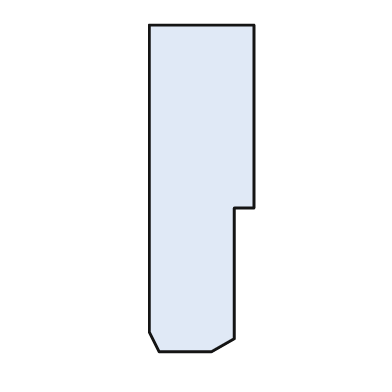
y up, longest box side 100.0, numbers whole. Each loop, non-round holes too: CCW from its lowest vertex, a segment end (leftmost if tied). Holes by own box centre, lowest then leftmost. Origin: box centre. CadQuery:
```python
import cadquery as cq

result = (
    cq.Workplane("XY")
    .moveTo(-13.0, -50.0)
    .lineTo(3.0, -50.0)
    .lineTo(10.0, -46.0)
    .lineTo(10.0, -6.0)
    .lineTo(16.0, -6.0)
    .lineTo(16.0, 50.0)
    .lineTo(-16.0, 50.0)
    .lineTo(-16.0, -44.0)
    .close()
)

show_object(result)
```